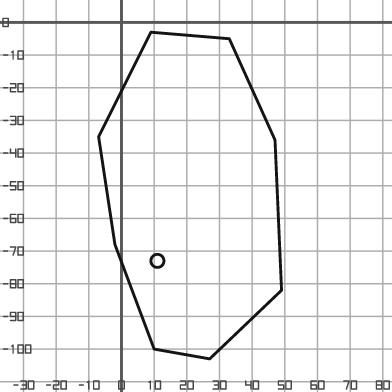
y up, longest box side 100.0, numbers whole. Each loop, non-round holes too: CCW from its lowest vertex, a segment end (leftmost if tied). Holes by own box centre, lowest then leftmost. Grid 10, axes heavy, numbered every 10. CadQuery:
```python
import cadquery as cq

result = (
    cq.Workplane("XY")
    .moveTo(27.0, -103.0)
    .lineTo(49.0, -82.0)
    .lineTo(47.0, -36.0)
    .lineTo(33.0, -5.0)
    .lineTo(9.0, -3.0)
    .lineTo(-7.0, -35.0)
    .lineTo(-2.0, -68.0)
    .lineTo(10.0, -100.0)
    .close()
    .moveTo(11.0, -73.0)
    .circle(2.0)
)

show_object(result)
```